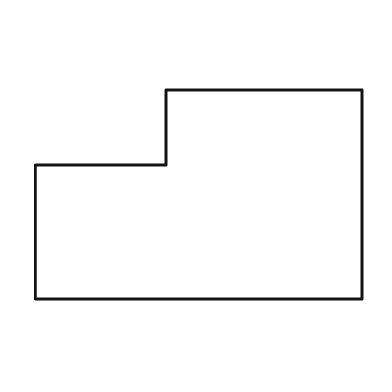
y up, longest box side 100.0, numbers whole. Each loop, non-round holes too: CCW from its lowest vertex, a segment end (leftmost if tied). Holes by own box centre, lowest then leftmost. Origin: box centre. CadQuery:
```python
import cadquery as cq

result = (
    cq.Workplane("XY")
    .moveTo(-50.0, -32.0)
    .lineTo(50.0, -32.0)
    .lineTo(50.0, 32.0)
    .lineTo(-10.0, 32.0)
    .lineTo(-10.0, 9.0)
    .lineTo(-50.0, 9.0)
    .close()
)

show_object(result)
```